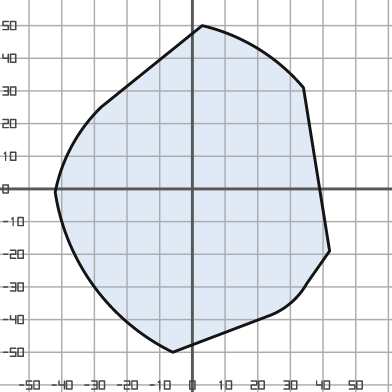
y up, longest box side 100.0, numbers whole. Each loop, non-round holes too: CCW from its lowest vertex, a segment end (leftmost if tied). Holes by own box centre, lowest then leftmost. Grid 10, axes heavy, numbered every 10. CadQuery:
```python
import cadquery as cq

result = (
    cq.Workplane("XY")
    .moveTo(-6.0, -50.0)
    .lineTo(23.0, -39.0)
    .threePointArc((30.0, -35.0), (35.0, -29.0))
    .lineTo(42.0, -19.0)
    .lineTo(34.0, 31.0)
    .threePointArc((20.0, 43.0), (3.0, 50.0))
    .lineTo(-28.0, 25.0)
    .threePointArc((-37.0, 13.0), (-42.0, -1.0))
    .threePointArc((-30.0, -30.0), (-6.0, -50.0))
    .close()
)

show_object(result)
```